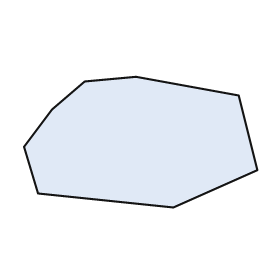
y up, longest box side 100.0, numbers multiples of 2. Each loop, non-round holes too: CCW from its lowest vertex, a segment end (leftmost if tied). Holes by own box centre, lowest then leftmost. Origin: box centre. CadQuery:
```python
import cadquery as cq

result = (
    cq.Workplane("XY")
    .moveTo(14.0, -28.0)
    .lineTo(50.0, -12.0)
    .lineTo(42.0, 20.0)
    .lineTo(-2.0, 28.0)
    .lineTo(-24.0, 26.0)
    .lineTo(-38.0, 14.0)
    .lineTo(-50.0, -2.0)
    .lineTo(-44.0, -22.0)
    .close()
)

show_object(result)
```